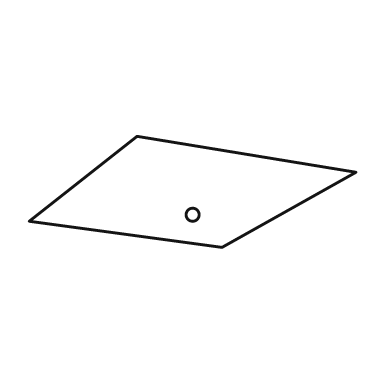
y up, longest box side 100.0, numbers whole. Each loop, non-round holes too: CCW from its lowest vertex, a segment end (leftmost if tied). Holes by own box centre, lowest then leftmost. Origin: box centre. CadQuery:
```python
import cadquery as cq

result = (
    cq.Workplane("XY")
    .moveTo(9.0, -17.0)
    .lineTo(50.0, 6.0)
    .lineTo(-17.0, 17.0)
    .lineTo(-50.0, -9.0)
    .close()
    .moveTo(0.0, -7.0)
    .circle(2.0)
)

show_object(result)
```